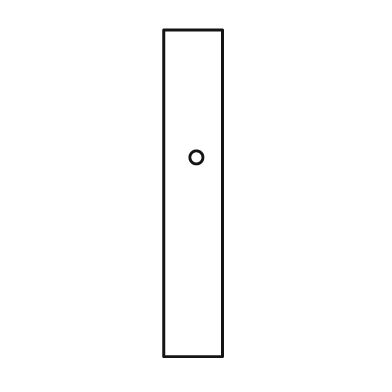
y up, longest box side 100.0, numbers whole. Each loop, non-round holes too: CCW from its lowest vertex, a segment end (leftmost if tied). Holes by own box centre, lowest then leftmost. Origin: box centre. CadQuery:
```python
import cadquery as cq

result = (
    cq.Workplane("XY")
    .moveTo(-9.0, -50.0)
    .lineTo(9.0, -50.0)
    .lineTo(9.0, 50.0)
    .lineTo(-9.0, 50.0)
    .close()
    .moveTo(1.0, 11.0)
    .circle(2.0)
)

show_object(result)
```